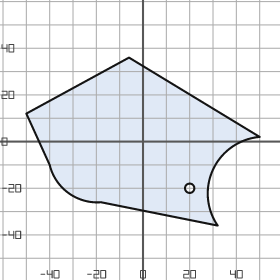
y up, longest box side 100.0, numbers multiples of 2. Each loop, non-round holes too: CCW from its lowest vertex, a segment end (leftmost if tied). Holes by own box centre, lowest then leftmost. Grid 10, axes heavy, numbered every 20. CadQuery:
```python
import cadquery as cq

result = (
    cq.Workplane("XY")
    .moveTo(32.0, -36.0)
    .threePointArc((30.0, -12.0), (50.0, 2.0))
    .lineTo(-6.0, 36.0)
    .lineTo(-50.0, 12.0)
    .lineTo(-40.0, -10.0)
    .threePointArc((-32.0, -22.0), (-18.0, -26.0))
    .close()
    .moveTo(20.0, -20.0)
    .circle(2.0)
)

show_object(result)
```